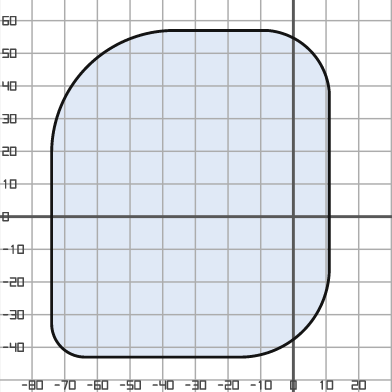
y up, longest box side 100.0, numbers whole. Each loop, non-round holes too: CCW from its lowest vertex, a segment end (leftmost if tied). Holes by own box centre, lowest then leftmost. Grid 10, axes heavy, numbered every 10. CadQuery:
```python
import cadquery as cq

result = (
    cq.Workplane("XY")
    .moveTo(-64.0, -43.0)
    .lineTo(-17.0, -43.0)
    .threePointArc((3.0, -35.0), (11.0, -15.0))
    .lineTo(11.0, 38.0)
    .threePointArc((5.0, 51.0), (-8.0, 57.0))
    .lineTo(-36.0, 57.0)
    .threePointArc((-63.0, 46.0), (-74.0, 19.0))
    .lineTo(-74.0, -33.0)
    .threePointArc((-71.0, -40.0), (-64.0, -43.0))
    .close()
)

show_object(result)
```